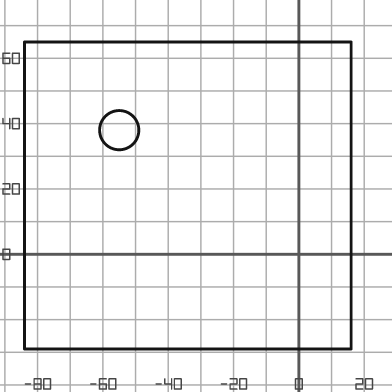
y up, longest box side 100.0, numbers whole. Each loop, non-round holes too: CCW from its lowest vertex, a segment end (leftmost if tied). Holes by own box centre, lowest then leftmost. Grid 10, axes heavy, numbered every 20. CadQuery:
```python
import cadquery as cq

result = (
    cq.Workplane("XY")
    .moveTo(-84.0, -29.0)
    .lineTo(16.0, -29.0)
    .lineTo(16.0, 65.0)
    .lineTo(-84.0, 65.0)
    .close()
    .moveTo(-55.0, 38.0)
    .circle(6.0)
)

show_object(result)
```